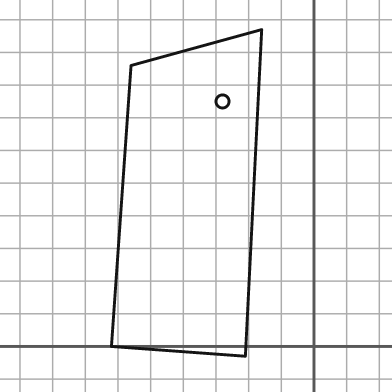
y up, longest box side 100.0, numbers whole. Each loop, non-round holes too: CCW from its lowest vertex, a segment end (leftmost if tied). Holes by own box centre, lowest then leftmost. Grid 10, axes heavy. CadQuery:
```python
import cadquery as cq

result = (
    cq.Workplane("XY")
    .moveTo(-21.0, -3.0)
    .lineTo(-16.0, 97.0)
    .lineTo(-56.0, 86.0)
    .lineTo(-62.0, 0.0)
    .close()
    .moveTo(-28.0, 75.0)
    .circle(2.0)
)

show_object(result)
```